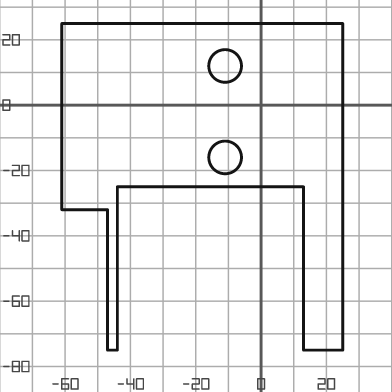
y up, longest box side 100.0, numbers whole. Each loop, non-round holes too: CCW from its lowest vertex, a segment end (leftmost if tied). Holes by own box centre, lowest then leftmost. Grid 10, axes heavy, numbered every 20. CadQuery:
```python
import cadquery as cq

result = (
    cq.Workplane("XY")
    .moveTo(-47.0, -75.0)
    .lineTo(-44.0, -75.0)
    .lineTo(-44.0, -25.0)
    .lineTo(13.0, -25.0)
    .lineTo(13.0, -75.0)
    .lineTo(25.0, -75.0)
    .lineTo(25.0, 25.0)
    .lineTo(-61.0, 25.0)
    .lineTo(-61.0, -32.0)
    .lineTo(-47.0, -32.0)
    .close()
    .moveTo(-11.0, -16.0)
    .circle(5.0)
    .moveTo(-11.0, 12.0)
    .circle(5.0)
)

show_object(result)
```